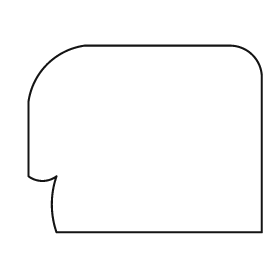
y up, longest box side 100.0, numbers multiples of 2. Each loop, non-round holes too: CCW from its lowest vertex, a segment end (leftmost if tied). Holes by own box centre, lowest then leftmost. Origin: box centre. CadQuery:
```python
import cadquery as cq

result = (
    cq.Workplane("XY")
    .moveTo(-38.0, -40.0)
    .lineTo(50.0, -40.0)
    .lineTo(50.0, 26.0)
    .threePointArc((46.0, 36.0), (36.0, 40.0))
    .lineTo(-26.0, 40.0)
    .threePointArc((-42.0, 32.0), (-50.0, 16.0))
    .lineTo(-50.0, -16.0)
    .threePointArc((-44.0, -18.0), (-38.0, -16.0))
    .threePointArc((-40.0, -28.0), (-38.0, -40.0))
    .close()
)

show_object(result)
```